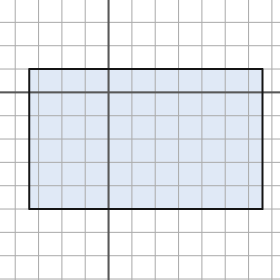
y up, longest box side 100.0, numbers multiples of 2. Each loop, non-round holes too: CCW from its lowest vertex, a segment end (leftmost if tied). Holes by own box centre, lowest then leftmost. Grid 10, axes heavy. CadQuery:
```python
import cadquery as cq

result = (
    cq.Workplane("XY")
    .moveTo(-34.0, -50.0)
    .lineTo(66.0, -50.0)
    .lineTo(66.0, 10.0)
    .lineTo(-34.0, 10.0)
    .close()
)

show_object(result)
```